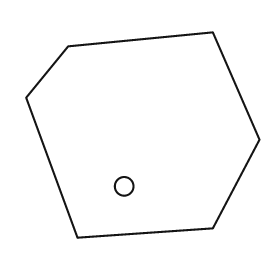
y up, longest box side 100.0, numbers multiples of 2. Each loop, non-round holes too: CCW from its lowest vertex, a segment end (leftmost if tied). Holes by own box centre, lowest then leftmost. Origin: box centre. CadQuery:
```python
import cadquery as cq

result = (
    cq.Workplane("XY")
    .moveTo(-28.0, -44.0)
    .lineTo(30.0, -40.0)
    .lineTo(50.0, -2.0)
    .lineTo(30.0, 44.0)
    .lineTo(-32.0, 38.0)
    .lineTo(-50.0, 16.0)
    .close()
    .moveTo(-8.0, -22.0)
    .circle(4.0)
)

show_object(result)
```